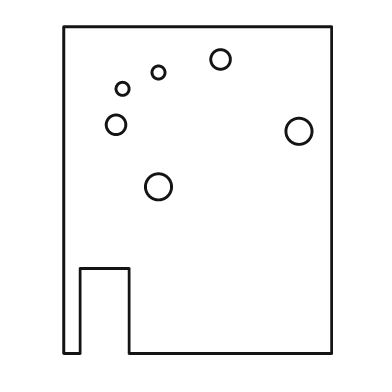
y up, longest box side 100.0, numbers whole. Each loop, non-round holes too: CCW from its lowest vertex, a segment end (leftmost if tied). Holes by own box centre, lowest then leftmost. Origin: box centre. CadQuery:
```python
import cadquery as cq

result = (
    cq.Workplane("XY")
    .moveTo(-41.0, -50.0)
    .lineTo(-36.0, -50.0)
    .lineTo(-36.0, -24.0)
    .lineTo(-21.0, -24.0)
    .lineTo(-21.0, -50.0)
    .lineTo(41.0, -50.0)
    .lineTo(41.0, 50.0)
    .lineTo(-41.0, 50.0)
    .close()
    .moveTo(-12.0, 1.0)
    .circle(4.0)
    .moveTo(31.0, 18.0)
    .circle(4.0)
    .moveTo(-25.0, 20.0)
    .circle(3.0)
    .moveTo(-23.0, 31.0)
    .circle(2.0)
    .moveTo(-12.0, 36.0)
    .circle(2.0)
    .moveTo(7.0, 40.0)
    .circle(3.0)
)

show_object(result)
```